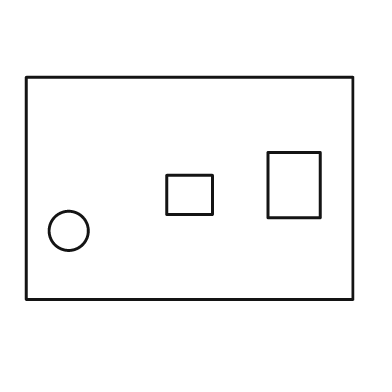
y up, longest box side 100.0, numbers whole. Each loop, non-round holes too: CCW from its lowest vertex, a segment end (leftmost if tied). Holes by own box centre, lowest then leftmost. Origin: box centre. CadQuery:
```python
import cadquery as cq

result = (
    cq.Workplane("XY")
    .moveTo(-50.0, -34.0)
    .lineTo(50.0, -34.0)
    .lineTo(50.0, 34.0)
    .lineTo(-50.0, 34.0)
    .close()
    .moveTo(-37.0, -13.0)
    .circle(6.0)
    .moveTo(-7.0, -8.0)
    .lineTo(7.0, -8.0)
    .lineTo(7.0, 4.0)
    .lineTo(-7.0, 4.0)
    .close()
    .moveTo(24.0, -9.0)
    .lineTo(40.0, -9.0)
    .lineTo(40.0, 11.0)
    .lineTo(24.0, 11.0)
    .close()
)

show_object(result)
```